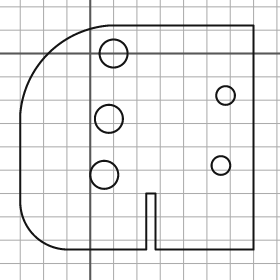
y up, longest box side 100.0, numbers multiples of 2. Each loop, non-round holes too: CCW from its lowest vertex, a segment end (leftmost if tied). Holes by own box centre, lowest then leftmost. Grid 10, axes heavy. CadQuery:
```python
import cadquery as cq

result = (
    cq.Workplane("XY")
    .moveTo(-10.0, -84.0)
    .lineTo(24.0, -84.0)
    .lineTo(24.0, -60.0)
    .lineTo(28.0, -60.0)
    .lineTo(28.0, -84.0)
    .lineTo(70.0, -84.0)
    .lineTo(70.0, 12.0)
    .lineTo(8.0, 12.0)
    .threePointArc((-18.0, 0.0), (-30.0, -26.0))
    .lineTo(-30.0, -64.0)
    .threePointArc((-24.0, -78.0), (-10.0, -84.0))
    .close()
    .moveTo(6.0, -52.0)
    .circle(6.0)
    .moveTo(56.0, -48.0)
    .circle(4.0)
    .moveTo(8.0, -28.0)
    .circle(6.0)
    .moveTo(58.0, -18.0)
    .circle(4.0)
    .moveTo(10.0, 0.0)
    .circle(6.0)
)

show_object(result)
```